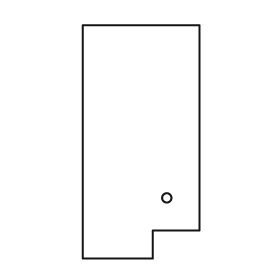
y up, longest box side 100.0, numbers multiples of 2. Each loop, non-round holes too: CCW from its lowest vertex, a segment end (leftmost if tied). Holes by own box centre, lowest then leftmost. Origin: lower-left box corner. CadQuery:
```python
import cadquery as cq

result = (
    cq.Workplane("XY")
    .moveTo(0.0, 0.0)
    .lineTo(30.0, 0.0)
    .lineTo(30.0, 12.0)
    .lineTo(50.0, 12.0)
    .lineTo(50.0, 100.0)
    .lineTo(0.0, 100.0)
    .close()
    .moveTo(36.0, 26.0)
    .circle(2.0)
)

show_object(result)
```